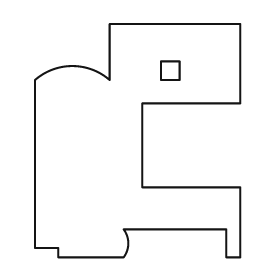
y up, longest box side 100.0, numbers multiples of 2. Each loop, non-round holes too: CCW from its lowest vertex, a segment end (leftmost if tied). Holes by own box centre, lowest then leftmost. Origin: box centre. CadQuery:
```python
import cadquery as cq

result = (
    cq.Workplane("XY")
    .moveTo(-34.0, -50.0)
    .lineTo(-6.0, -50.0)
    .threePointArc((-4.0, -44.0), (-6.0, -38.0))
    .lineTo(38.0, -38.0)
    .lineTo(38.0, -50.0)
    .lineTo(44.0, -50.0)
    .lineTo(44.0, -20.0)
    .lineTo(2.0, -20.0)
    .lineTo(2.0, 16.0)
    .lineTo(44.0, 16.0)
    .lineTo(44.0, 50.0)
    .lineTo(-12.0, 50.0)
    .lineTo(-12.0, 26.0)
    .threePointArc((-28.0, 32.0), (-44.0, 26.0))
    .lineTo(-44.0, -46.0)
    .lineTo(-34.0, -46.0)
    .close()
    .moveTo(10.0, 26.0)
    .lineTo(18.0, 26.0)
    .lineTo(18.0, 34.0)
    .lineTo(10.0, 34.0)
    .close()
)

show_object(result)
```